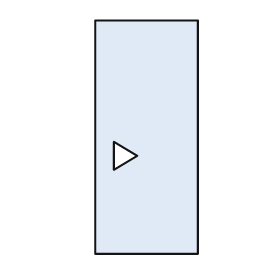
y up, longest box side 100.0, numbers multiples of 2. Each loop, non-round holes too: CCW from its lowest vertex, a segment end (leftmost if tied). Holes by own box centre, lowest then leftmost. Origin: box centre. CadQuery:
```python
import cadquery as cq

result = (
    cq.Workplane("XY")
    .moveTo(-22.0, -50.0)
    .lineTo(22.0, -50.0)
    .lineTo(22.0, 50.0)
    .lineTo(-22.0, 50.0)
    .close()
    .moveTo(-14.0, -14.0)
    .lineTo(-4.0, -8.0)
    .lineTo(-14.0, -2.0)
    .close()
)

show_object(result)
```